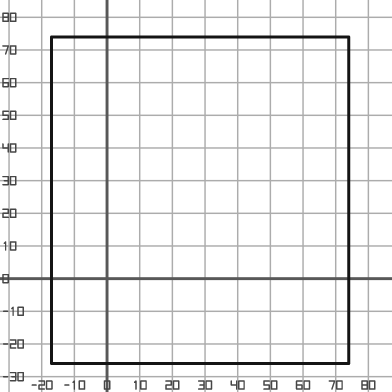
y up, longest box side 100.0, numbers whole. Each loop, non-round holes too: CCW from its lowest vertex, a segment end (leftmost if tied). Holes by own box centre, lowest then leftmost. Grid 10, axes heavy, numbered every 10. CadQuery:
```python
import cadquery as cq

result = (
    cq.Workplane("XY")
    .moveTo(-17.0, -26.0)
    .lineTo(74.0, -26.0)
    .lineTo(74.0, 74.0)
    .lineTo(-17.0, 74.0)
    .close()
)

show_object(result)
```